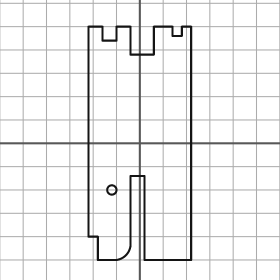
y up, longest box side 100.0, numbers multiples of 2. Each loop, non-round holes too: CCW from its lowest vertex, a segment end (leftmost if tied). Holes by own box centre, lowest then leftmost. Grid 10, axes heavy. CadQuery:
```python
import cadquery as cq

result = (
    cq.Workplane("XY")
    .moveTo(-18.0, -50.0)
    .lineTo(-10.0, -50.0)
    .threePointArc((-6.0, -48.0), (-4.0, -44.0))
    .lineTo(-4.0, -14.0)
    .lineTo(2.0, -14.0)
    .lineTo(2.0, -50.0)
    .lineTo(22.0, -50.0)
    .lineTo(22.0, 50.0)
    .lineTo(18.0, 50.0)
    .lineTo(18.0, 46.0)
    .lineTo(14.0, 46.0)
    .lineTo(14.0, 50.0)
    .lineTo(6.0, 50.0)
    .lineTo(6.0, 38.0)
    .lineTo(-4.0, 38.0)
    .lineTo(-4.0, 50.0)
    .lineTo(-10.0, 50.0)
    .lineTo(-10.0, 44.0)
    .lineTo(-16.0, 44.0)
    .lineTo(-16.0, 50.0)
    .lineTo(-22.0, 50.0)
    .lineTo(-22.0, -40.0)
    .lineTo(-18.0, -40.0)
    .close()
    .moveTo(-12.0, -20.0)
    .circle(2.0)
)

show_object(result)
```